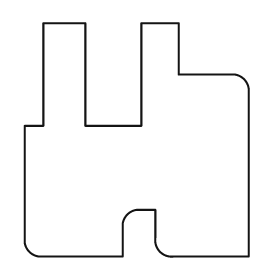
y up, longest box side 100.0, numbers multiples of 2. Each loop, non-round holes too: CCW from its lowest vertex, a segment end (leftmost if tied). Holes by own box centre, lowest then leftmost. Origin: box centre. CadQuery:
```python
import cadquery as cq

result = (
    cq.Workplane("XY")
    .moveTo(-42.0, -50.0)
    .lineTo(-6.0, -50.0)
    .lineTo(-6.0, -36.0)
    .threePointArc((-4.0, -32.0), (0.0, -30.0))
    .lineTo(8.0, -30.0)
    .lineTo(8.0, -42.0)
    .threePointArc((10.0, -48.0), (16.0, -50.0))
    .lineTo(48.0, -50.0)
    .lineTo(48.0, 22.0)
    .threePointArc((46.0, 26.0), (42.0, 28.0))
    .lineTo(18.0, 28.0)
    .lineTo(18.0, 50.0)
    .lineTo(2.0, 50.0)
    .lineTo(2.0, 6.0)
    .lineTo(-22.0, 6.0)
    .lineTo(-22.0, 50.0)
    .lineTo(-40.0, 50.0)
    .lineTo(-40.0, 6.0)
    .lineTo(-48.0, 6.0)
    .lineTo(-48.0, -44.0)
    .threePointArc((-46.0, -48.0), (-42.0, -50.0))
    .close()
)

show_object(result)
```